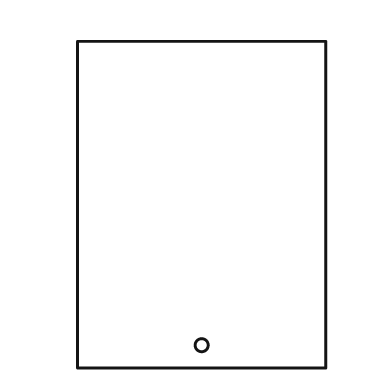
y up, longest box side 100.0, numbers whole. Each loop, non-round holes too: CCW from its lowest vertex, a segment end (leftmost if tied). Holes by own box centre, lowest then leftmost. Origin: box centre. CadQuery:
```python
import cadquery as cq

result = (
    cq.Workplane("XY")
    .moveTo(-38.0, -50.0)
    .lineTo(38.0, -50.0)
    .lineTo(38.0, 50.0)
    .lineTo(-38.0, 50.0)
    .close()
    .moveTo(0.0, -43.0)
    .circle(2.0)
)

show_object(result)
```